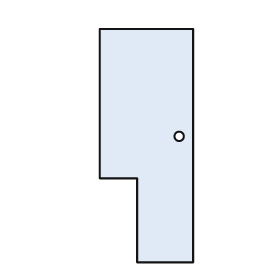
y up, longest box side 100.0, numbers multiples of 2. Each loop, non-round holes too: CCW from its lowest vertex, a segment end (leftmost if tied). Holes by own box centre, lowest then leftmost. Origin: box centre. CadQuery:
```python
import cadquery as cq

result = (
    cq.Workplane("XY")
    .moveTo(-4.0, -50.0)
    .lineTo(20.0, -50.0)
    .lineTo(20.0, 50.0)
    .lineTo(-20.0, 50.0)
    .lineTo(-20.0, -14.0)
    .lineTo(-4.0, -14.0)
    .close()
    .moveTo(14.0, 4.0)
    .circle(2.0)
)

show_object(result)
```